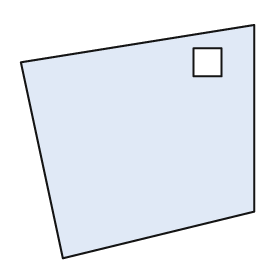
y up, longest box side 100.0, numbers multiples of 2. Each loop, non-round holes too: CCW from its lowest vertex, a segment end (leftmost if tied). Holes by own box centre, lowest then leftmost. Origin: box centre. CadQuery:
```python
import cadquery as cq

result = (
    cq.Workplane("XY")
    .moveTo(-32.0, -50.0)
    .lineTo(50.0, -30.0)
    .lineTo(50.0, 50.0)
    .lineTo(-50.0, 34.0)
    .close()
    .moveTo(24.0, 28.0)
    .lineTo(36.0, 28.0)
    .lineTo(36.0, 40.0)
    .lineTo(24.0, 40.0)
    .close()
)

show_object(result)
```